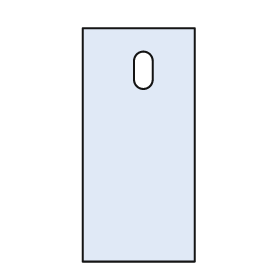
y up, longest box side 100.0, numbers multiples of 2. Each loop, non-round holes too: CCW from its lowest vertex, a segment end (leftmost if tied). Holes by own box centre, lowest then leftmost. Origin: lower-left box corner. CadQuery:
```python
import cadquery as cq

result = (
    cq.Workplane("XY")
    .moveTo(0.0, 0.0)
    .lineTo(48.0, 0.0)
    .lineTo(48.0, 100.0)
    .lineTo(0.0, 100.0)
    .close()
    .moveTo(22.0, 78.0)
    .threePointArc((26.0, 74.0), (30.0, 78.0))
    .lineTo(30.0, 86.0)
    .threePointArc((26.0, 90.0), (22.0, 86.0))
    .close()
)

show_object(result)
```